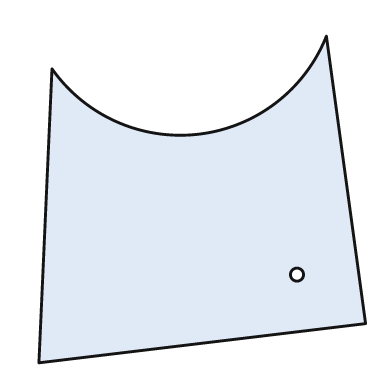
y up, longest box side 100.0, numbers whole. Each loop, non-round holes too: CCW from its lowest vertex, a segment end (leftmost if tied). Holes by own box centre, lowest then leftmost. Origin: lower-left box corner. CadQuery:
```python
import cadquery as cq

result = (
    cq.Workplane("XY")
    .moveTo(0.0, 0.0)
    .lineTo(100.0, 12.0)
    .lineTo(88.0, 100.0)
    .threePointArc((49.0, 70.0), (4.0, 90.0))
    .close()
    .moveTo(79.0, 27.0)
    .circle(2.0)
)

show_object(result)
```